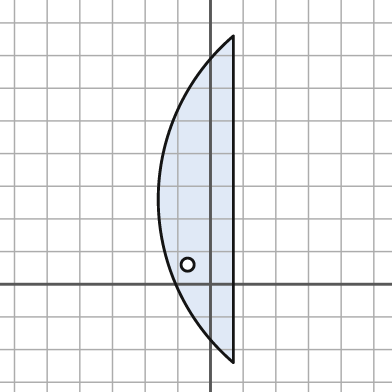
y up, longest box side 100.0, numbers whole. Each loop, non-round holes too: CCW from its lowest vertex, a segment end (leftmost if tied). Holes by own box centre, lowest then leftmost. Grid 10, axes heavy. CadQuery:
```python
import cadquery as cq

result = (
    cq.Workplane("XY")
    .moveTo(7.0, -24.0)
    .lineTo(7.0, 76.0)
    .threePointArc((-16.0, 26.0), (7.0, -24.0))
    .close()
    .moveTo(-7.0, 6.0)
    .circle(2.0)
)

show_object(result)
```